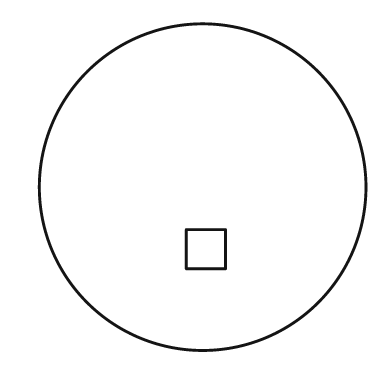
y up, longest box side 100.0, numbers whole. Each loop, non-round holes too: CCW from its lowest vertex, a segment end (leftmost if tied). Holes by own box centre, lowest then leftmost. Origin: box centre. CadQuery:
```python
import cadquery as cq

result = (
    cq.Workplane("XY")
    .moveTo(0.0, 0.0)
    .circle(50.0)
    .moveTo(-5.0, -25.0)
    .lineTo(7.0, -25.0)
    .lineTo(7.0, -13.0)
    .lineTo(-5.0, -13.0)
    .close()
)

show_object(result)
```